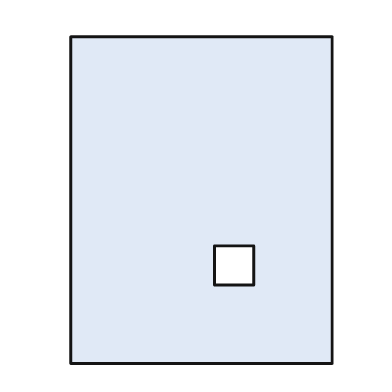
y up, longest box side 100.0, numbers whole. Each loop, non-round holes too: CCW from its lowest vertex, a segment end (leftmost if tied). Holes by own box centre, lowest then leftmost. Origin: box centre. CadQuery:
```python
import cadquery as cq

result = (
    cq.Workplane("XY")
    .moveTo(-40.0, -50.0)
    .lineTo(40.0, -50.0)
    .lineTo(40.0, 50.0)
    .lineTo(-40.0, 50.0)
    .close()
    .moveTo(4.0, -26.0)
    .lineTo(16.0, -26.0)
    .lineTo(16.0, -14.0)
    .lineTo(4.0, -14.0)
    .close()
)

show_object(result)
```